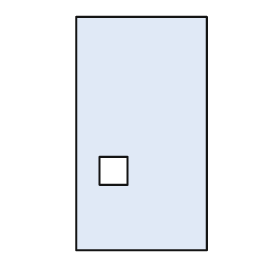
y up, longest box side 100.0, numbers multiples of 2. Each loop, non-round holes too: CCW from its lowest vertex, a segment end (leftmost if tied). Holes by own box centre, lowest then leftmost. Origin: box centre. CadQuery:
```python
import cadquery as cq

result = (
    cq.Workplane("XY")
    .moveTo(-28.0, -50.0)
    .lineTo(28.0, -50.0)
    .lineTo(28.0, 50.0)
    .lineTo(-28.0, 50.0)
    .close()
    .moveTo(-18.0, -22.0)
    .lineTo(-6.0, -22.0)
    .lineTo(-6.0, -10.0)
    .lineTo(-18.0, -10.0)
    .close()
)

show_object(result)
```